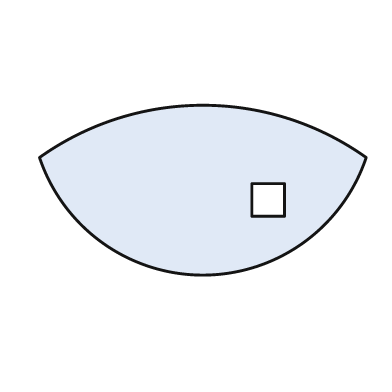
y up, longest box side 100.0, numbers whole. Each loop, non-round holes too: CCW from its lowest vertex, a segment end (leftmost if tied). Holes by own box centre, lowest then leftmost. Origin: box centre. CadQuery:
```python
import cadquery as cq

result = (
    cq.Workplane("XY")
    .moveTo(-50.0, 10.0)
    .threePointArc((0.0, -26.0), (50.0, 10.0))
    .threePointArc((0.0, 26.0), (-50.0, 10.0))
    .close()
    .moveTo(15.0, -8.0)
    .lineTo(25.0, -8.0)
    .lineTo(25.0, 2.0)
    .lineTo(15.0, 2.0)
    .close()
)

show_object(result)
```